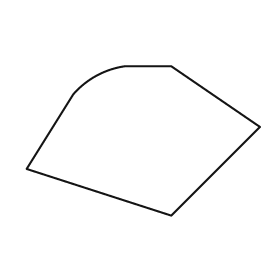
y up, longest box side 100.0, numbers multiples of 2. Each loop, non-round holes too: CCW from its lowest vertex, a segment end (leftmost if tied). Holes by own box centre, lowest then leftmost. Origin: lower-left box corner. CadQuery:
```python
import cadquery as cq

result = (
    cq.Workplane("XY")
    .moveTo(62.0, 0.0)
    .lineTo(100.0, 38.0)
    .lineTo(62.0, 64.0)
    .lineTo(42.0, 64.0)
    .threePointArc((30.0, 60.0), (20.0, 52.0))
    .lineTo(0.0, 20.0)
    .close()
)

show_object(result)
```